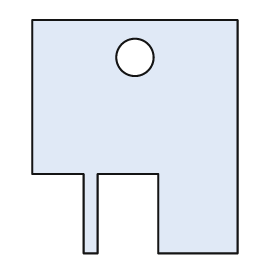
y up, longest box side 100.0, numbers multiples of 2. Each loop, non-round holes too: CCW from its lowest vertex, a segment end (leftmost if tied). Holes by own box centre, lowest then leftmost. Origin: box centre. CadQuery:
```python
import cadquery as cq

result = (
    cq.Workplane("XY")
    .moveTo(-22.0, -50.0)
    .lineTo(-16.0, -50.0)
    .lineTo(-16.0, -16.0)
    .lineTo(10.0, -16.0)
    .lineTo(10.0, -50.0)
    .lineTo(44.0, -50.0)
    .lineTo(44.0, 50.0)
    .lineTo(-44.0, 50.0)
    .lineTo(-44.0, -16.0)
    .lineTo(-22.0, -16.0)
    .close()
    .moveTo(0.0, 34.0)
    .circle(8.0)
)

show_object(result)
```